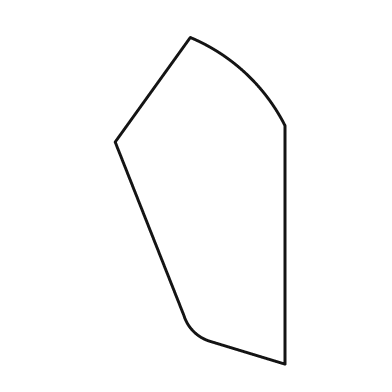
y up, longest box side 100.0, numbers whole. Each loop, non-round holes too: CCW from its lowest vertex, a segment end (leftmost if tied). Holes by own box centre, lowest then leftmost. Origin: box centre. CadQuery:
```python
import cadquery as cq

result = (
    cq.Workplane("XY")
    .moveTo(26.0, -50.0)
    .lineTo(26.0, 23.0)
    .threePointArc((14.0, 39.0), (-3.0, 50.0))
    .lineTo(-26.0, 18.0)
    .lineTo(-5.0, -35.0)
    .threePointArc((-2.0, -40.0), (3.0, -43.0))
    .close()
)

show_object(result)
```